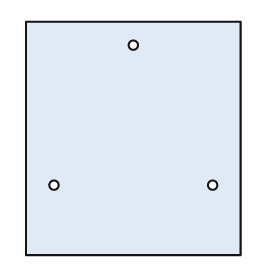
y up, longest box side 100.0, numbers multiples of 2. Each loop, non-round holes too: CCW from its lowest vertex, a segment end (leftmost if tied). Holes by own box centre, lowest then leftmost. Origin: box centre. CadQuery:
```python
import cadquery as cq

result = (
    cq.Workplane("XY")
    .moveTo(-46.0, -50.0)
    .lineTo(46.0, -50.0)
    .lineTo(46.0, 50.0)
    .lineTo(-46.0, 50.0)
    .close()
    .moveTo(-34.0, -20.0)
    .circle(2.0)
    .moveTo(34.0, -20.0)
    .circle(2.0)
    .moveTo(0.0, 40.0)
    .circle(2.0)
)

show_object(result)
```